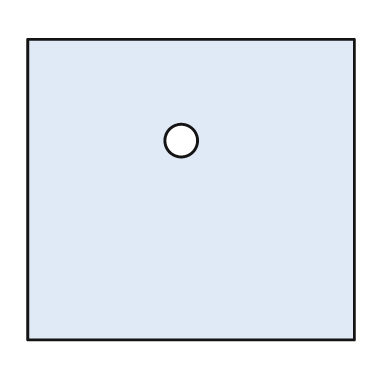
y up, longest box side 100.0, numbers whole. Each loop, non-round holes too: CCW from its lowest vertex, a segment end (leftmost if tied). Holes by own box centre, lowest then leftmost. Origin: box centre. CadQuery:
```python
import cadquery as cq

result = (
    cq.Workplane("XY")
    .moveTo(-50.0, -46.0)
    .lineTo(50.0, -46.0)
    .lineTo(50.0, 46.0)
    .lineTo(-50.0, 46.0)
    .close()
    .moveTo(-3.0, 15.0)
    .circle(5.0)
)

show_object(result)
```